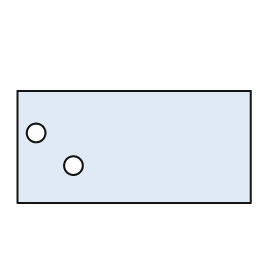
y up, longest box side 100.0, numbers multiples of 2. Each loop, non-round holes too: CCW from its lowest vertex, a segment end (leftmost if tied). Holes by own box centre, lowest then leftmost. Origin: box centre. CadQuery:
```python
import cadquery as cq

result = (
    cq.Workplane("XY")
    .moveTo(-50.0, -24.0)
    .lineTo(50.0, -24.0)
    .lineTo(50.0, 24.0)
    .lineTo(-50.0, 24.0)
    .close()
    .moveTo(-26.0, -8.0)
    .circle(4.0)
    .moveTo(-42.0, 6.0)
    .circle(4.0)
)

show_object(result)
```